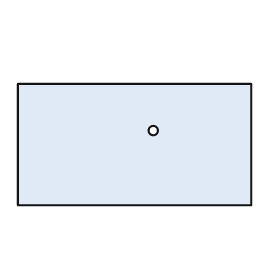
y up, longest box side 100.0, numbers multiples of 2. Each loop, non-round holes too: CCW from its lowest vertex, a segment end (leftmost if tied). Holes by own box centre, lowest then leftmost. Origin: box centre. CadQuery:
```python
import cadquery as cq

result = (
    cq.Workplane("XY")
    .moveTo(-50.0, -26.0)
    .lineTo(50.0, -26.0)
    .lineTo(50.0, 26.0)
    .lineTo(-50.0, 26.0)
    .close()
    .moveTo(8.0, 6.0)
    .circle(2.0)
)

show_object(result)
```